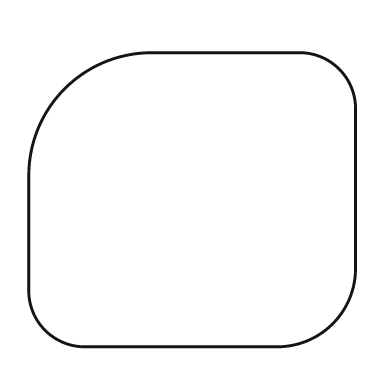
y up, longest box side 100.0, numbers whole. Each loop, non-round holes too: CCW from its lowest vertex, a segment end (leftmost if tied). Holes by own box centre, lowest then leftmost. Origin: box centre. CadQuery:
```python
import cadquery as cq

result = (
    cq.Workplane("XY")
    .moveTo(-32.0, -45.0)
    .lineTo(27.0, -45.0)
    .threePointArc((43.0, -38.0), (50.0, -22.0))
    .lineTo(50.0, 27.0)
    .threePointArc((45.0, 40.0), (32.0, 45.0))
    .lineTo(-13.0, 45.0)
    .threePointArc((-39.0, 34.0), (-50.0, 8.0))
    .lineTo(-50.0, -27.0)
    .threePointArc((-45.0, -40.0), (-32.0, -45.0))
    .close()
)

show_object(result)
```